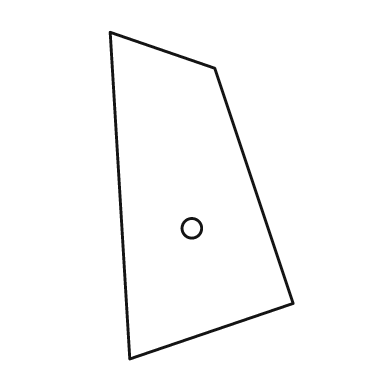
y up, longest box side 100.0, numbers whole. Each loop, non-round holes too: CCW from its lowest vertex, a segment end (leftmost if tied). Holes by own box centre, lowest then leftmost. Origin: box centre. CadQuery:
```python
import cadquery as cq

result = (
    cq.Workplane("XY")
    .moveTo(-22.0, -50.0)
    .lineTo(28.0, -33.0)
    .lineTo(4.0, 39.0)
    .lineTo(-28.0, 50.0)
    .close()
    .moveTo(-3.0, -10.0)
    .circle(3.0)
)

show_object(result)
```